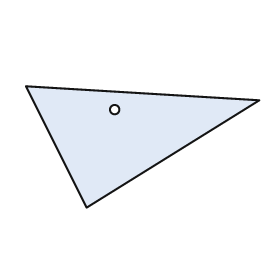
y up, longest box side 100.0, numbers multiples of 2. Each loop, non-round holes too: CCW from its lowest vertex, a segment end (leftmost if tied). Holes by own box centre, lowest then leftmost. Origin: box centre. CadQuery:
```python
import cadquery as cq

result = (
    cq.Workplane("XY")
    .moveTo(-24.0, -26.0)
    .lineTo(50.0, 20.0)
    .lineTo(-50.0, 26.0)
    .close()
    .moveTo(-12.0, 16.0)
    .circle(2.0)
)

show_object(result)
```